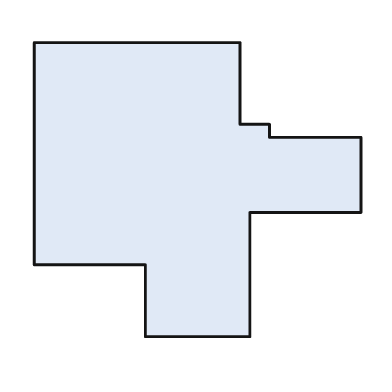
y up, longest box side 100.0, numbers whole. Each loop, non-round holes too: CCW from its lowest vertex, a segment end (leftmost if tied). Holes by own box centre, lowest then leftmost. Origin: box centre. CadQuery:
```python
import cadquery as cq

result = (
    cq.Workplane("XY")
    .moveTo(-16.0, -45.0)
    .lineTo(16.0, -45.0)
    .lineTo(16.0, -7.0)
    .lineTo(50.0, -7.0)
    .lineTo(50.0, 16.0)
    .lineTo(22.0, 16.0)
    .lineTo(22.0, 20.0)
    .lineTo(13.0, 20.0)
    .lineTo(13.0, 45.0)
    .lineTo(-50.0, 45.0)
    .lineTo(-50.0, -23.0)
    .lineTo(-16.0, -23.0)
    .close()
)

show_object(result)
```